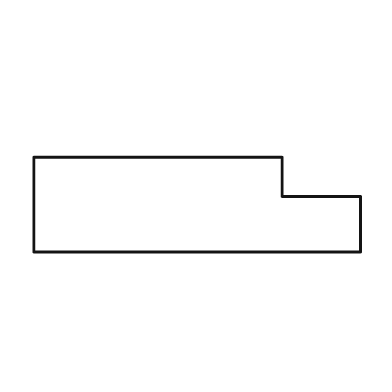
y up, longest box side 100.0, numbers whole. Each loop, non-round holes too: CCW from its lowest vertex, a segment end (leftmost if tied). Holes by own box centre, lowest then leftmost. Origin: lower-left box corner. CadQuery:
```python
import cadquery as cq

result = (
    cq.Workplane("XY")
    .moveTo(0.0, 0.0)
    .lineTo(100.0, 0.0)
    .lineTo(100.0, 17.0)
    .lineTo(76.0, 17.0)
    .lineTo(76.0, 29.0)
    .lineTo(0.0, 29.0)
    .close()
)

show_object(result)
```